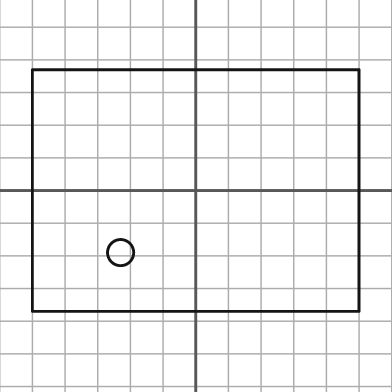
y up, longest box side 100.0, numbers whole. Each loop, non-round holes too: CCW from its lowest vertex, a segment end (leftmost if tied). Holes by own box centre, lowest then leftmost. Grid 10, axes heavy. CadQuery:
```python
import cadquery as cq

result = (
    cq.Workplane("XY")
    .moveTo(-50.0, -37.0)
    .lineTo(50.0, -37.0)
    .lineTo(50.0, 37.0)
    .lineTo(-50.0, 37.0)
    .close()
    .moveTo(-23.0, -19.0)
    .circle(4.0)
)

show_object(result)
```